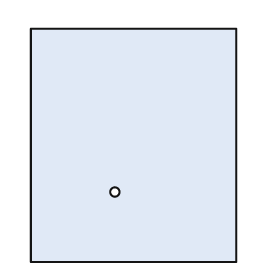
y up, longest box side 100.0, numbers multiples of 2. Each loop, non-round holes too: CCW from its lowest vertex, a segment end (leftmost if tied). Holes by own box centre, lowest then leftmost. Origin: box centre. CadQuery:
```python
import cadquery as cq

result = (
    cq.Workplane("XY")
    .moveTo(-44.0, -50.0)
    .lineTo(44.0, -50.0)
    .lineTo(44.0, 50.0)
    .lineTo(-44.0, 50.0)
    .close()
    .moveTo(-8.0, -20.0)
    .circle(2.0)
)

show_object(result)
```